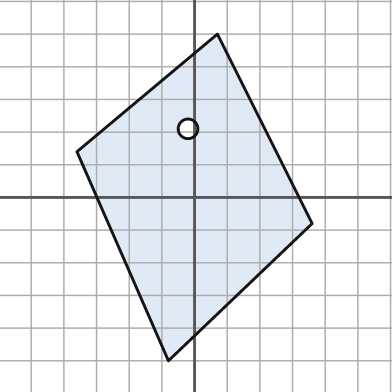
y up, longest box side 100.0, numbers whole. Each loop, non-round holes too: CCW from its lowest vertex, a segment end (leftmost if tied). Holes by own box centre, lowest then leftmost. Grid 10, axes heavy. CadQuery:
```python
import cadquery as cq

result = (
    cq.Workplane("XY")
    .moveTo(-8.0, -50.0)
    .lineTo(36.0, -8.0)
    .lineTo(7.0, 50.0)
    .lineTo(-36.0, 14.0)
    .close()
    .moveTo(-2.0, 21.0)
    .circle(3.0)
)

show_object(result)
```